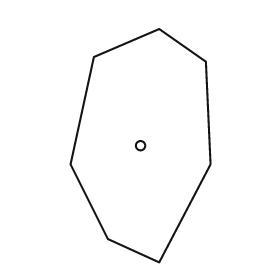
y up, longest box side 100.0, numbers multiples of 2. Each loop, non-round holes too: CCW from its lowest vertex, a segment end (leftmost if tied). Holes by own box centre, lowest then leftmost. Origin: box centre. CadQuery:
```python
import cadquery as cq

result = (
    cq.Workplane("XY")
    .moveTo(8.0, -50.0)
    .lineTo(30.0, -8.0)
    .lineTo(28.0, 36.0)
    .lineTo(8.0, 50.0)
    .lineTo(-20.0, 38.0)
    .lineTo(-30.0, -8.0)
    .lineTo(-14.0, -40.0)
    .close()
    .moveTo(0.0, 0.0)
    .circle(2.0)
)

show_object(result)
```